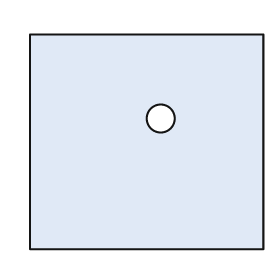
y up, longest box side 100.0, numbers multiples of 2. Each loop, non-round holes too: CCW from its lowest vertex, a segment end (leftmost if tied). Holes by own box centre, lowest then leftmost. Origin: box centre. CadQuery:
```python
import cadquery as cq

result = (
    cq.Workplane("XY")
    .moveTo(-50.0, -46.0)
    .lineTo(50.0, -46.0)
    .lineTo(50.0, 46.0)
    .lineTo(-50.0, 46.0)
    .close()
    .moveTo(6.0, 10.0)
    .circle(6.0)
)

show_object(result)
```